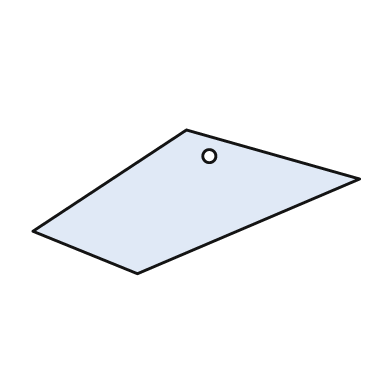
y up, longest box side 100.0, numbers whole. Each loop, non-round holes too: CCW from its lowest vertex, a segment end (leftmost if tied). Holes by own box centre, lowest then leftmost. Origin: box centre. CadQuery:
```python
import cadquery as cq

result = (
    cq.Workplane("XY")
    .moveTo(-18.0, -22.0)
    .lineTo(50.0, 7.0)
    .lineTo(-3.0, 22.0)
    .lineTo(-50.0, -9.0)
    .close()
    .moveTo(4.0, 14.0)
    .circle(2.0)
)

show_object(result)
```